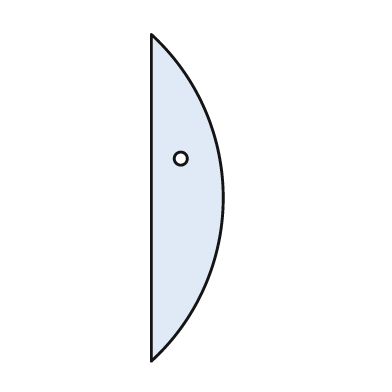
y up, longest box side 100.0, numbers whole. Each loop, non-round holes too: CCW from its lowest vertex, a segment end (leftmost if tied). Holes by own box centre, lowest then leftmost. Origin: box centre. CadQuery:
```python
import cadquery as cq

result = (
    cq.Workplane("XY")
    .moveTo(-11.0, -50.0)
    .threePointArc((11.0, 0.0), (-11.0, 50.0))
    .close()
    .moveTo(-2.0, 12.0)
    .circle(2.0)
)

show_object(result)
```